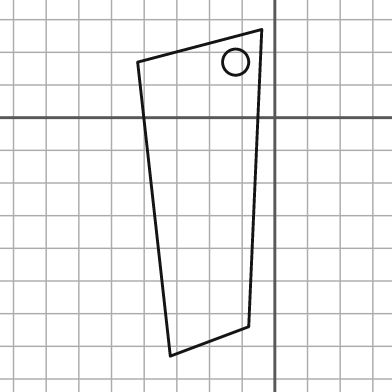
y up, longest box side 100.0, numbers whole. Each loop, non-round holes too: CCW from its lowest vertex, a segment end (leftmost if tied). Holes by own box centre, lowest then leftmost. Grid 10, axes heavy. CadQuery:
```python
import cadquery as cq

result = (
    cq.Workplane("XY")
    .moveTo(-32.0, -73.0)
    .lineTo(-8.0, -64.0)
    .lineTo(-4.0, 27.0)
    .lineTo(-42.0, 17.0)
    .close()
    .moveTo(-12.0, 17.0)
    .circle(4.0)
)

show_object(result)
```